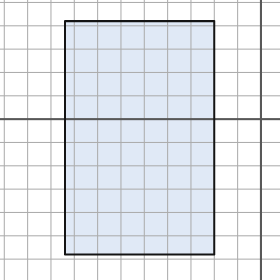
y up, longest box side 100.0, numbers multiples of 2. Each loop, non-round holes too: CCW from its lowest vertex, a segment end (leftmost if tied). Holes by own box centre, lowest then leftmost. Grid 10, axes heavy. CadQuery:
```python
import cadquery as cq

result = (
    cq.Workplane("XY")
    .moveTo(-84.0, -58.0)
    .lineTo(-20.0, -58.0)
    .lineTo(-20.0, 42.0)
    .lineTo(-84.0, 42.0)
    .close()
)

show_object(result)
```